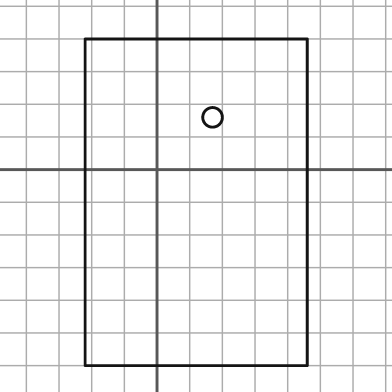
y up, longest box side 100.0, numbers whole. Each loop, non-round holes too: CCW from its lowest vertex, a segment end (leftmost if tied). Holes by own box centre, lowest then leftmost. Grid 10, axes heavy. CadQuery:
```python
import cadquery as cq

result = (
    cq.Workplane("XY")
    .moveTo(-22.0, -60.0)
    .lineTo(46.0, -60.0)
    .lineTo(46.0, 40.0)
    .lineTo(-22.0, 40.0)
    .close()
    .moveTo(17.0, 16.0)
    .circle(3.0)
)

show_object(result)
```